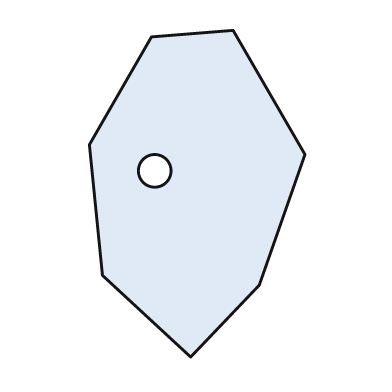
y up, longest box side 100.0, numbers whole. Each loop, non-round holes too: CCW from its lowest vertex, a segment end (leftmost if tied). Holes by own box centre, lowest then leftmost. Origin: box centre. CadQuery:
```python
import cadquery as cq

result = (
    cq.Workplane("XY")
    .moveTo(-2.0, -50.0)
    .lineTo(19.0, -28.0)
    .lineTo(33.0, 12.0)
    .lineTo(11.0, 50.0)
    .lineTo(-14.0, 48.0)
    .lineTo(-33.0, 15.0)
    .lineTo(-29.0, -25.0)
    .close()
    .moveTo(-13.0, 7.0)
    .circle(5.0)
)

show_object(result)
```